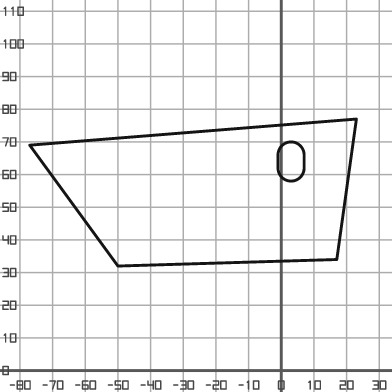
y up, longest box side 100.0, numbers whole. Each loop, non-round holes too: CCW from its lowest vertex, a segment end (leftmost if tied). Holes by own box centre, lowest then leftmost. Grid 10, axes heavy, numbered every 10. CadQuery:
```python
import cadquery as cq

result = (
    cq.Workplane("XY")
    .moveTo(-50.0, 32.0)
    .lineTo(17.0, 34.0)
    .lineTo(23.0, 77.0)
    .lineTo(-77.0, 69.0)
    .close()
    .moveTo(-1.0, 62.0)
    .threePointArc((3.0, 58.0), (7.0, 62.0))
    .lineTo(7.0, 66.0)
    .threePointArc((3.0, 70.0), (-1.0, 66.0))
    .close()
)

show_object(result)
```